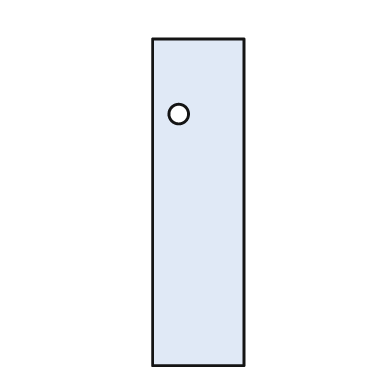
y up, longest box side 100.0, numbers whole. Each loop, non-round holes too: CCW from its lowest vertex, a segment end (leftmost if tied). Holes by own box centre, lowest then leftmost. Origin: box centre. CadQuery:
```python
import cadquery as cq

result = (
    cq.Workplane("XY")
    .moveTo(-14.0, -50.0)
    .lineTo(14.0, -50.0)
    .lineTo(14.0, 50.0)
    .lineTo(-14.0, 50.0)
    .close()
    .moveTo(-6.0, 27.0)
    .circle(3.0)
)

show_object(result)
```